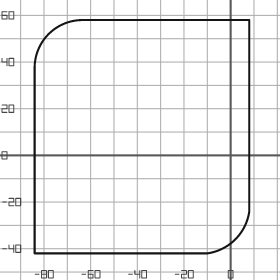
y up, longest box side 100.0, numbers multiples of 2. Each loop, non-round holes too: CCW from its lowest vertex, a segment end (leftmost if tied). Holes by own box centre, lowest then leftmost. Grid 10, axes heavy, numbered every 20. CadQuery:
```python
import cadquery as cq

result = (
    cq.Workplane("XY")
    .moveTo(-84.0, -42.0)
    .lineTo(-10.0, -42.0)
    .threePointArc((2.0, -36.0), (8.0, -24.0))
    .lineTo(8.0, 58.0)
    .lineTo(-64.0, 58.0)
    .threePointArc((-78.0, 52.0), (-84.0, 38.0))
    .close()
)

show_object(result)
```